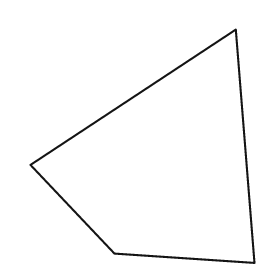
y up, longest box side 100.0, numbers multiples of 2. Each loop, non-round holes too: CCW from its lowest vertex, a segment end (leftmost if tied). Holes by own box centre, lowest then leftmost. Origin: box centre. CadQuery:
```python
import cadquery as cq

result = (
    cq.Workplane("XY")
    .moveTo(48.0, -50.0)
    .lineTo(40.0, 50.0)
    .lineTo(-48.0, -8.0)
    .lineTo(-12.0, -46.0)
    .close()
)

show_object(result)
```